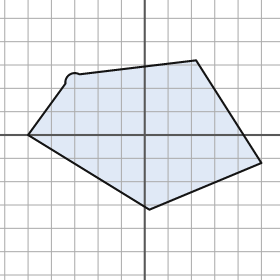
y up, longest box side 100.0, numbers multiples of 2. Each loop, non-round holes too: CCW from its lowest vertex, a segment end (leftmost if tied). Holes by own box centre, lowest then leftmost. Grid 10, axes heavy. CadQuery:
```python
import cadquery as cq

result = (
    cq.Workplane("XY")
    .moveTo(2.0, -32.0)
    .lineTo(50.0, -12.0)
    .lineTo(22.0, 32.0)
    .lineTo(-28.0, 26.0)
    .threePointArc((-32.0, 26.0), (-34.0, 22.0))
    .lineTo(-50.0, 0.0)
    .close()
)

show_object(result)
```